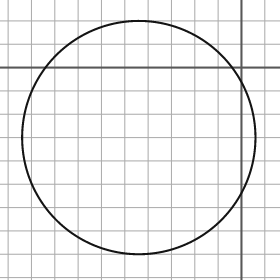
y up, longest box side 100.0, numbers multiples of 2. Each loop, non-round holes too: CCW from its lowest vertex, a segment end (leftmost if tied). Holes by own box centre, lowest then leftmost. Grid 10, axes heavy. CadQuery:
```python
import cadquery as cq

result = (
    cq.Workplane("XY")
    .moveTo(-44.0, -30.0)
    .circle(50.0)
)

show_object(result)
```